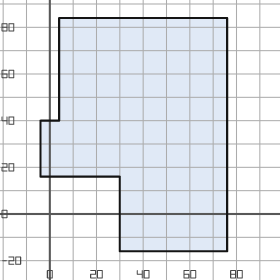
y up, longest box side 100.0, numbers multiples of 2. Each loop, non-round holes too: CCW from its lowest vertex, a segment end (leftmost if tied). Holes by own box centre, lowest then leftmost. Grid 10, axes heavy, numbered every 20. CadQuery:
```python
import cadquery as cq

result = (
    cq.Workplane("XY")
    .moveTo(30.0, -16.0)
    .lineTo(76.0, -16.0)
    .lineTo(76.0, 84.0)
    .lineTo(4.0, 84.0)
    .lineTo(4.0, 40.0)
    .lineTo(-4.0, 40.0)
    .lineTo(-4.0, 16.0)
    .lineTo(30.0, 16.0)
    .close()
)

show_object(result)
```